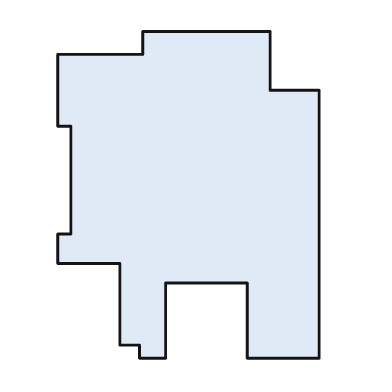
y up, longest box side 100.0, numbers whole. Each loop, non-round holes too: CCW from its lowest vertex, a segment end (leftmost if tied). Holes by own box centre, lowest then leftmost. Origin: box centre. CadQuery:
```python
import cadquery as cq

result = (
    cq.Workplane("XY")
    .moveTo(-15.0, -50.0)
    .lineTo(-7.0, -50.0)
    .lineTo(-7.0, -27.0)
    .lineTo(18.0, -27.0)
    .lineTo(18.0, -50.0)
    .lineTo(40.0, -50.0)
    .lineTo(40.0, 32.0)
    .lineTo(25.0, 32.0)
    .lineTo(25.0, 50.0)
    .lineTo(-14.0, 50.0)
    .lineTo(-14.0, 43.0)
    .lineTo(-40.0, 43.0)
    .lineTo(-40.0, 21.0)
    .lineTo(-36.0, 21.0)
    .lineTo(-36.0, -12.0)
    .lineTo(-40.0, -12.0)
    .lineTo(-40.0, -21.0)
    .lineTo(-21.0, -21.0)
    .lineTo(-21.0, -46.0)
    .lineTo(-15.0, -46.0)
    .close()
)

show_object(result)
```